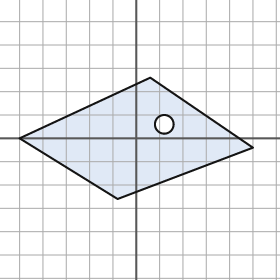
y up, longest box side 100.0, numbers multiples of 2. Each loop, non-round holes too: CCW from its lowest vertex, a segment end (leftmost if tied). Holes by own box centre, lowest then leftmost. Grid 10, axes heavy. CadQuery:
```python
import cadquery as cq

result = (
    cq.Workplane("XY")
    .moveTo(-8.0, -26.0)
    .lineTo(50.0, -4.0)
    .lineTo(6.0, 26.0)
    .lineTo(-50.0, 0.0)
    .close()
    .moveTo(12.0, 6.0)
    .circle(4.0)
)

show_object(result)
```